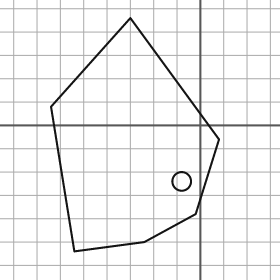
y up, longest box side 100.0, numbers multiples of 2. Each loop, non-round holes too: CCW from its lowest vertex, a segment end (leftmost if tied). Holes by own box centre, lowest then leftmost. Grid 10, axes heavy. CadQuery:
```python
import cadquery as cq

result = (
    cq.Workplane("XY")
    .moveTo(-54.0, -54.0)
    .lineTo(-24.0, -50.0)
    .lineTo(-2.0, -38.0)
    .lineTo(8.0, -6.0)
    .lineTo(-30.0, 46.0)
    .lineTo(-64.0, 8.0)
    .close()
    .moveTo(-8.0, -24.0)
    .circle(4.0)
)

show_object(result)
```